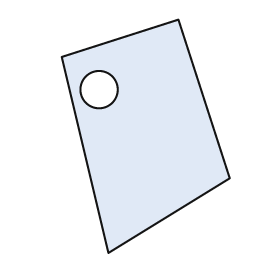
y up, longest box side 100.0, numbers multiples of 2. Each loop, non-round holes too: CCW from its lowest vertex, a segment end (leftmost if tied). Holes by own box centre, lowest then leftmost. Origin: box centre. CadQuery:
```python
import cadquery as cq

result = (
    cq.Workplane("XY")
    .moveTo(-16.0, -50.0)
    .lineTo(36.0, -18.0)
    .lineTo(14.0, 50.0)
    .lineTo(-36.0, 34.0)
    .close()
    .moveTo(-20.0, 20.0)
    .circle(8.0)
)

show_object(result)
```